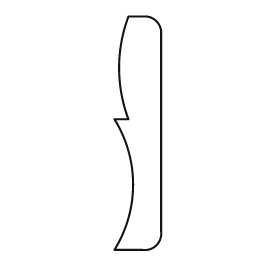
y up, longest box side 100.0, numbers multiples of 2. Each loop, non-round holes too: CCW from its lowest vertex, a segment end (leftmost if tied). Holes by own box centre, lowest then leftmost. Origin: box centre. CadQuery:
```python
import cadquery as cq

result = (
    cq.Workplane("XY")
    .moveTo(-10.0, -50.0)
    .lineTo(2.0, -50.0)
    .threePointArc((8.0, -48.0), (10.0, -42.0))
    .lineTo(10.0, 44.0)
    .threePointArc((8.0, 48.0), (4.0, 50.0))
    .lineTo(-4.0, 50.0)
    .threePointArc((-8.0, 28.0), (-4.0, 6.0))
    .lineTo(-10.0, 6.0)
    .threePointArc((-2.0, -22.0), (-10.0, -50.0))
    .close()
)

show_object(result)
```